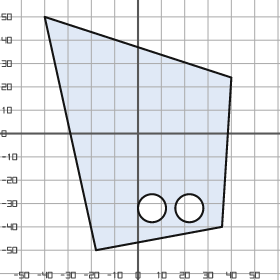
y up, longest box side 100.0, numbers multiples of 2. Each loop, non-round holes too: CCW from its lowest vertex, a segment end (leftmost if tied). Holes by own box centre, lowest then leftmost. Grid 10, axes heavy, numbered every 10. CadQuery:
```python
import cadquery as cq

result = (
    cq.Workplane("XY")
    .moveTo(-18.0, -50.0)
    .lineTo(36.0, -40.0)
    .lineTo(40.0, 24.0)
    .lineTo(-40.0, 50.0)
    .close()
    .moveTo(6.0, -32.0)
    .circle(6.0)
    .moveTo(22.0, -32.0)
    .circle(6.0)
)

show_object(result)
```